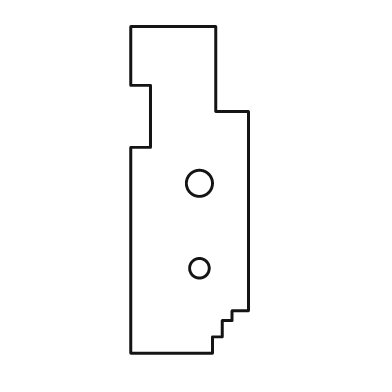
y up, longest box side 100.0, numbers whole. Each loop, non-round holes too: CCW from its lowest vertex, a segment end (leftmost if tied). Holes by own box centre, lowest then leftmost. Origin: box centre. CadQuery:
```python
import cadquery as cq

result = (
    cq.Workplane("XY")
    .moveTo(-18.0, -50.0)
    .lineTo(7.0, -50.0)
    .lineTo(7.0, -45.0)
    .lineTo(10.0, -45.0)
    .lineTo(10.0, -40.0)
    .lineTo(13.0, -40.0)
    .lineTo(13.0, -37.0)
    .lineTo(18.0, -37.0)
    .lineTo(18.0, 24.0)
    .lineTo(8.0, 24.0)
    .lineTo(8.0, 50.0)
    .lineTo(-18.0, 50.0)
    .lineTo(-18.0, 32.0)
    .lineTo(-12.0, 32.0)
    .lineTo(-12.0, 13.0)
    .lineTo(-18.0, 13.0)
    .close()
    .moveTo(3.0, -24.0)
    .circle(3.0)
    .moveTo(3.0, 2.0)
    .circle(4.0)
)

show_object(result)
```